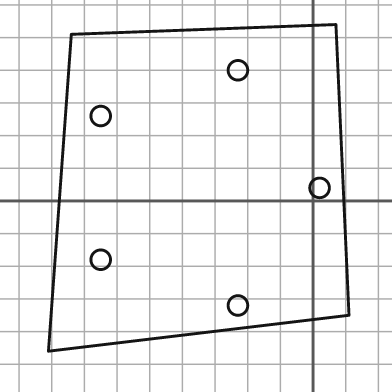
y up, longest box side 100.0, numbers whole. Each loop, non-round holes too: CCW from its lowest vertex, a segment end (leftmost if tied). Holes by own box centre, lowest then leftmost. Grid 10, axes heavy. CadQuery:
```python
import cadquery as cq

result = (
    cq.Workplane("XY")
    .moveTo(-81.0, -46.0)
    .lineTo(11.0, -35.0)
    .lineTo(7.0, 54.0)
    .lineTo(-74.0, 51.0)
    .close()
    .moveTo(-23.0, -32.0)
    .circle(3.0)
    .moveTo(-65.0, -18.0)
    .circle(3.0)
    .moveTo(2.0, 4.0)
    .circle(3.0)
    .moveTo(-65.0, 26.0)
    .circle(3.0)
    .moveTo(-23.0, 40.0)
    .circle(3.0)
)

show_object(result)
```